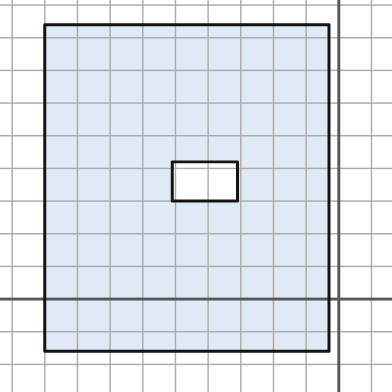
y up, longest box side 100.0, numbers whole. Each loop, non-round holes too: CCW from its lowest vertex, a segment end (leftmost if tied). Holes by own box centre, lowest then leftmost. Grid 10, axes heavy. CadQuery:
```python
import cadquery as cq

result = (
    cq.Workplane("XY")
    .moveTo(-90.0, -16.0)
    .lineTo(-3.0, -16.0)
    .lineTo(-3.0, 84.0)
    .lineTo(-90.0, 84.0)
    .close()
    .moveTo(-51.0, 30.0)
    .lineTo(-31.0, 30.0)
    .lineTo(-31.0, 42.0)
    .lineTo(-51.0, 42.0)
    .close()
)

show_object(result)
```